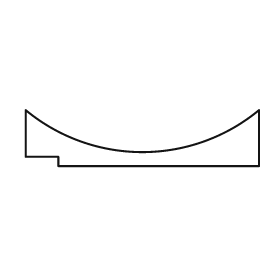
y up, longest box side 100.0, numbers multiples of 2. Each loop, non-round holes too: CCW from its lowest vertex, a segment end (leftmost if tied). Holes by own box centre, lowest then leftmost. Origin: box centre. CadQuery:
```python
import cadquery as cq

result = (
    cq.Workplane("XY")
    .moveTo(-36.0, -12.0)
    .lineTo(50.0, -12.0)
    .lineTo(50.0, 12.0)
    .threePointArc((0.0, -6.0), (-50.0, 12.0))
    .lineTo(-50.0, -8.0)
    .lineTo(-36.0, -8.0)
    .close()
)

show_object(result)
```